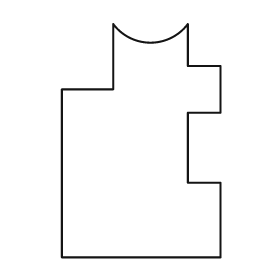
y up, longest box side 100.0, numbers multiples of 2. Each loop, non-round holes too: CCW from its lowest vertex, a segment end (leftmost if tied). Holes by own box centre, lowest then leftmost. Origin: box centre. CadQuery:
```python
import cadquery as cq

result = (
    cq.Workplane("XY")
    .moveTo(-34.0, -50.0)
    .lineTo(34.0, -50.0)
    .lineTo(34.0, -18.0)
    .lineTo(20.0, -18.0)
    .lineTo(20.0, 12.0)
    .lineTo(34.0, 12.0)
    .lineTo(34.0, 32.0)
    .lineTo(20.0, 32.0)
    .lineTo(20.0, 50.0)
    .threePointArc((4.0, 42.0), (-12.0, 50.0))
    .lineTo(-12.0, 22.0)
    .lineTo(-34.0, 22.0)
    .close()
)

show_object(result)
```